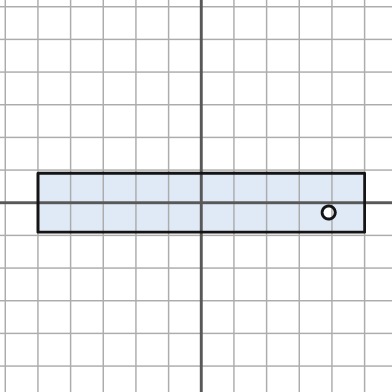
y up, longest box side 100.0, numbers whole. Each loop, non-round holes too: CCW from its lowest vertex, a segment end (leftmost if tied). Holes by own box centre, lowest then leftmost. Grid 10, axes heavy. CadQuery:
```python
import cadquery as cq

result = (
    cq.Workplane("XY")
    .moveTo(-50.0, -9.0)
    .lineTo(50.0, -9.0)
    .lineTo(50.0, 9.0)
    .lineTo(-50.0, 9.0)
    .close()
    .moveTo(39.0, -3.0)
    .circle(2.0)
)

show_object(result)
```